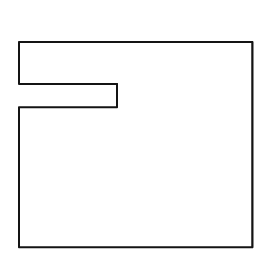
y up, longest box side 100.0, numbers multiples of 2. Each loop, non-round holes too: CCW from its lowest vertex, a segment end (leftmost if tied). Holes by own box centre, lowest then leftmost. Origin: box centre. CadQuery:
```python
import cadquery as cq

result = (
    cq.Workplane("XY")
    .moveTo(-50.0, -44.0)
    .lineTo(50.0, -44.0)
    .lineTo(50.0, 44.0)
    .lineTo(-50.0, 44.0)
    .lineTo(-50.0, 26.0)
    .lineTo(-8.0, 26.0)
    .lineTo(-8.0, 16.0)
    .lineTo(-50.0, 16.0)
    .close()
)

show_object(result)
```